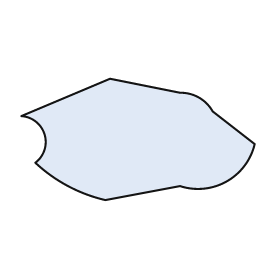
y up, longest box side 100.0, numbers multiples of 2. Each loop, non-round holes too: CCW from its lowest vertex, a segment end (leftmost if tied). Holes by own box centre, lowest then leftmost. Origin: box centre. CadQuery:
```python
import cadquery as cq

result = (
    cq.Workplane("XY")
    .moveTo(-14.0, -26.0)
    .lineTo(18.0, -20.0)
    .threePointArc((38.0, -18.0), (50.0, -2.0))
    .lineTo(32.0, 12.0)
    .threePointArc((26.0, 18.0), (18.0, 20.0))
    .lineTo(-12.0, 26.0)
    .lineTo(-50.0, 10.0)
    .threePointArc((-40.0, 2.0), (-44.0, -10.0))
    .threePointArc((-30.0, -20.0), (-14.0, -26.0))
    .close()
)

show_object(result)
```